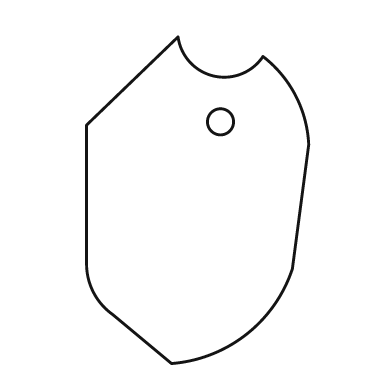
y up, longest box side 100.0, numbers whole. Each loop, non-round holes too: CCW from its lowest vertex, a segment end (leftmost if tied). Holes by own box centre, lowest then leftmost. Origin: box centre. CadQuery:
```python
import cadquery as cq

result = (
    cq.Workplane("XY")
    .moveTo(-8.0, -50.0)
    .threePointArc((15.0, -41.0), (29.0, -21.0))
    .lineTo(34.0, 17.0)
    .threePointArc((30.0, 32.0), (20.0, 44.0))
    .threePointArc((5.0, 38.0), (-6.0, 50.0))
    .lineTo(-34.0, 23.0)
    .lineTo(-34.0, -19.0)
    .threePointArc((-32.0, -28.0), (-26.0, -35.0))
    .close()
    .moveTo(7.0, 24.0)
    .circle(4.0)
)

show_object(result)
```